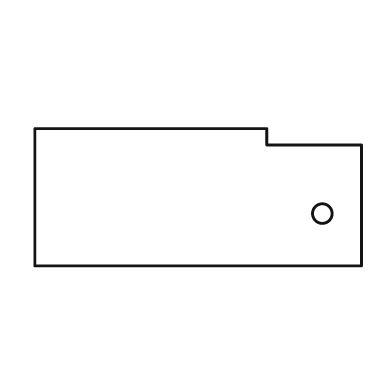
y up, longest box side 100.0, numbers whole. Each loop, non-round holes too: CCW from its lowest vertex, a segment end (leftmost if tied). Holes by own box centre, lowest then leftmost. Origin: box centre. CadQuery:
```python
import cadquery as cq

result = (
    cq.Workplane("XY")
    .moveTo(-50.0, -21.0)
    .lineTo(50.0, -21.0)
    .lineTo(50.0, 16.0)
    .lineTo(21.0, 16.0)
    .lineTo(21.0, 21.0)
    .lineTo(-50.0, 21.0)
    .close()
    .moveTo(38.0, -5.0)
    .circle(3.0)
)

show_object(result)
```